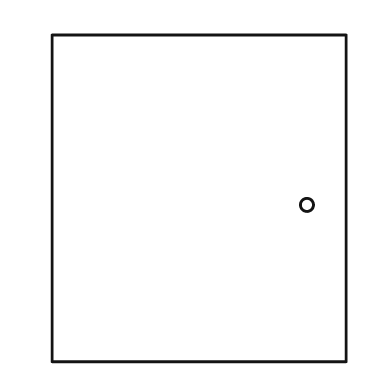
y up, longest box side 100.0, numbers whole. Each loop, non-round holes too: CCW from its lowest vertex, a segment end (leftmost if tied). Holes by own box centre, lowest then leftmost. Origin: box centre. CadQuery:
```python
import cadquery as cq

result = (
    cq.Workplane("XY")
    .moveTo(-45.0, -50.0)
    .lineTo(45.0, -50.0)
    .lineTo(45.0, 50.0)
    .lineTo(-45.0, 50.0)
    .close()
    .moveTo(33.0, -2.0)
    .circle(2.0)
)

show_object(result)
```